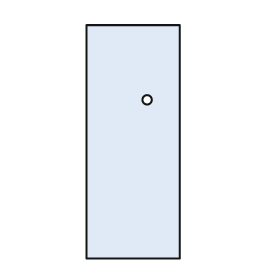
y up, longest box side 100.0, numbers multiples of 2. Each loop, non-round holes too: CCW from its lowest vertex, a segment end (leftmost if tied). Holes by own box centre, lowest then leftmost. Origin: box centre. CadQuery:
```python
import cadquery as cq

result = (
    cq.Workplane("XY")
    .moveTo(-20.0, -50.0)
    .lineTo(20.0, -50.0)
    .lineTo(20.0, 50.0)
    .lineTo(-20.0, 50.0)
    .close()
    .moveTo(6.0, 18.0)
    .circle(2.0)
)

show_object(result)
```